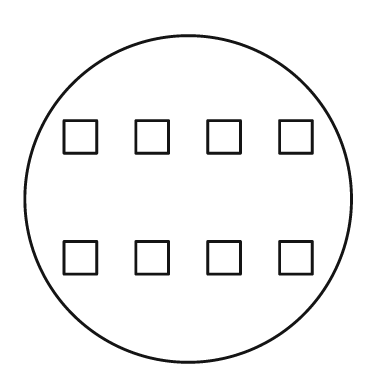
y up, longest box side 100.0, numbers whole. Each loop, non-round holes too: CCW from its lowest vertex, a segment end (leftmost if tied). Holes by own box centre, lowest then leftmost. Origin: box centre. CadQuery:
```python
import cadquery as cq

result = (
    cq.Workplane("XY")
    .moveTo(0.0, 0.0)
    .circle(50.0)
    .moveTo(-38.0, -23.0)
    .lineTo(-28.0, -23.0)
    .lineTo(-28.0, -13.0)
    .lineTo(-38.0, -13.0)
    .close()
    .moveTo(-16.0, -23.0)
    .lineTo(-6.0, -23.0)
    .lineTo(-6.0, -13.0)
    .lineTo(-16.0, -13.0)
    .close()
    .moveTo(6.0, -23.0)
    .lineTo(16.0, -23.0)
    .lineTo(16.0, -13.0)
    .lineTo(6.0, -13.0)
    .close()
    .moveTo(28.0, -23.0)
    .lineTo(38.0, -23.0)
    .lineTo(38.0, -13.0)
    .lineTo(28.0, -13.0)
    .close()
    .moveTo(-38.0, 14.0)
    .lineTo(-28.0, 14.0)
    .lineTo(-28.0, 24.0)
    .lineTo(-38.0, 24.0)
    .close()
    .moveTo(-16.0, 14.0)
    .lineTo(-6.0, 14.0)
    .lineTo(-6.0, 24.0)
    .lineTo(-16.0, 24.0)
    .close()
    .moveTo(6.0, 14.0)
    .lineTo(16.0, 14.0)
    .lineTo(16.0, 24.0)
    .lineTo(6.0, 24.0)
    .close()
    .moveTo(28.0, 14.0)
    .lineTo(38.0, 14.0)
    .lineTo(38.0, 24.0)
    .lineTo(28.0, 24.0)
    .close()
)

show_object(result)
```